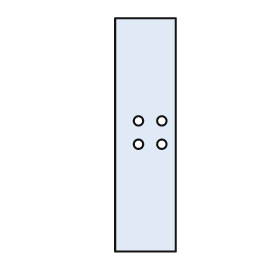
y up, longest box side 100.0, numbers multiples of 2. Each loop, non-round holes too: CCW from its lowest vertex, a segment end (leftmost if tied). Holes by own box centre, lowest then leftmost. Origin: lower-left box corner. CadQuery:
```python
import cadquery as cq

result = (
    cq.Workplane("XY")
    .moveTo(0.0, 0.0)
    .lineTo(26.0, 0.0)
    .lineTo(26.0, 100.0)
    .lineTo(0.0, 100.0)
    .close()
    .moveTo(10.0, 46.0)
    .circle(2.0)
    .moveTo(20.0, 46.0)
    .circle(2.0)
    .moveTo(10.0, 56.0)
    .circle(2.0)
    .moveTo(20.0, 56.0)
    .circle(2.0)
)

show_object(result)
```